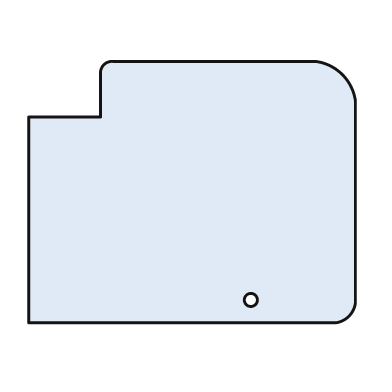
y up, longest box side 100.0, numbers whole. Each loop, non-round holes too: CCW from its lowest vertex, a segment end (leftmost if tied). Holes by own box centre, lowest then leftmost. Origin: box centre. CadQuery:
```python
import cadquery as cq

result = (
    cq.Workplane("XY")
    .moveTo(-50.0, -40.0)
    .lineTo(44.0, -40.0)
    .threePointArc((48.0, -38.0), (50.0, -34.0))
    .lineTo(50.0, 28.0)
    .threePointArc((46.0, 36.0), (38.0, 40.0))
    .lineTo(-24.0, 40.0)
    .threePointArc((-27.0, 39.0), (-28.0, 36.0))
    .lineTo(-28.0, 23.0)
    .lineTo(-50.0, 23.0)
    .close()
    .moveTo(18.0, -33.0)
    .circle(2.0)
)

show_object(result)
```